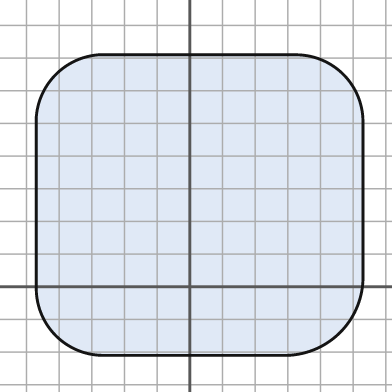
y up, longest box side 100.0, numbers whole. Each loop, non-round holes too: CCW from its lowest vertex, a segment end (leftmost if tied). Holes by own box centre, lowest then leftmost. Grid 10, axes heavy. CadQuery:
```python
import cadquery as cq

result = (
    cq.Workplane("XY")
    .moveTo(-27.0, -21.0)
    .lineTo(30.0, -21.0)
    .threePointArc((46.0, -14.0), (53.0, 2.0))
    .lineTo(53.0, 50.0)
    .threePointArc((47.0, 65.0), (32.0, 71.0))
    .lineTo(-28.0, 71.0)
    .threePointArc((-41.0, 65.0), (-47.0, 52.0))
    .lineTo(-47.0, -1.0)
    .threePointArc((-41.0, -15.0), (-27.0, -21.0))
    .close()
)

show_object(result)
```